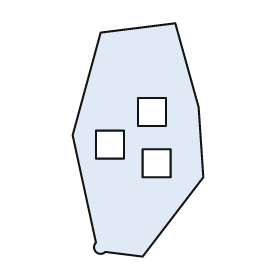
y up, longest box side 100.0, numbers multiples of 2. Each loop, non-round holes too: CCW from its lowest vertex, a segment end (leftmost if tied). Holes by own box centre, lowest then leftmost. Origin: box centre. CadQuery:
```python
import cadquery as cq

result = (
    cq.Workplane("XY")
    .moveTo(2.0, -50.0)
    .lineTo(28.0, -16.0)
    .lineTo(26.0, 14.0)
    .lineTo(16.0, 50.0)
    .lineTo(-16.0, 46.0)
    .lineTo(-28.0, 2.0)
    .lineTo(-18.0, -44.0)
    .threePointArc((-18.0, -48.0), (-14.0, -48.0))
    .close()
    .moveTo(2.0, -16.0)
    .lineTo(14.0, -16.0)
    .lineTo(14.0, -4.0)
    .lineTo(2.0, -4.0)
    .close()
    .moveTo(-18.0, -8.0)
    .lineTo(-6.0, -8.0)
    .lineTo(-6.0, 4.0)
    .lineTo(-18.0, 4.0)
    .close()
    .moveTo(0.0, 6.0)
    .lineTo(12.0, 6.0)
    .lineTo(12.0, 18.0)
    .lineTo(0.0, 18.0)
    .close()
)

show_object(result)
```